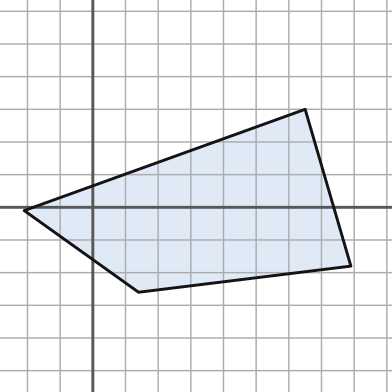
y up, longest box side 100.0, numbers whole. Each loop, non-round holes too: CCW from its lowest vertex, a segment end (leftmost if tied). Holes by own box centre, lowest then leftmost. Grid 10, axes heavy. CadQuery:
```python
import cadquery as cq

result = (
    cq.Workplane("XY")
    .moveTo(14.0, -26.0)
    .lineTo(79.0, -18.0)
    .lineTo(65.0, 30.0)
    .lineTo(-21.0, -1.0)
    .close()
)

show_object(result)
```